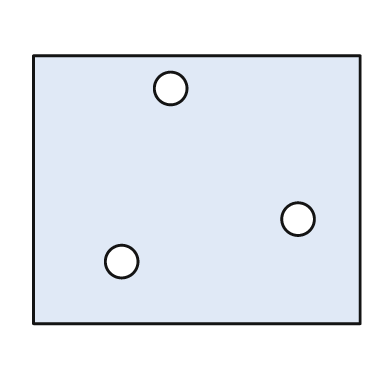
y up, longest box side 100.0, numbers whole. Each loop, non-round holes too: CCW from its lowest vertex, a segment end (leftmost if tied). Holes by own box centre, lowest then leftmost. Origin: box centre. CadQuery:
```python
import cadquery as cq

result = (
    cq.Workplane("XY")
    .moveTo(-50.0, -41.0)
    .lineTo(50.0, -41.0)
    .lineTo(50.0, 41.0)
    .lineTo(-50.0, 41.0)
    .close()
    .moveTo(-23.0, -22.0)
    .circle(5.0)
    .moveTo(31.0, -9.0)
    .circle(5.0)
    .moveTo(-8.0, 31.0)
    .circle(5.0)
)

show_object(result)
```